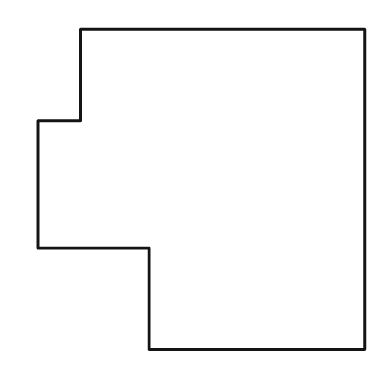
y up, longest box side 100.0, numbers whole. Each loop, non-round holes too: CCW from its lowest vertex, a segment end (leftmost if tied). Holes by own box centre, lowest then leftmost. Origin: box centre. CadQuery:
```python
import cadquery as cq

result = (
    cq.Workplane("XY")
    .moveTo(-16.0, -49.0)
    .lineTo(50.0, -49.0)
    .lineTo(50.0, 49.0)
    .lineTo(-37.0, 49.0)
    .lineTo(-37.0, 21.0)
    .lineTo(-50.0, 21.0)
    .lineTo(-50.0, -18.0)
    .lineTo(-16.0, -18.0)
    .close()
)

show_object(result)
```